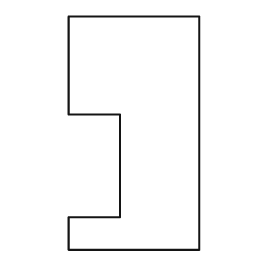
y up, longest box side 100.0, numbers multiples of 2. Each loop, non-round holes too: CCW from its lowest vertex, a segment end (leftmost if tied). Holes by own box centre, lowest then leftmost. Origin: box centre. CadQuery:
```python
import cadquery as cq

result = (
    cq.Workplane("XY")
    .moveTo(-28.0, -50.0)
    .lineTo(28.0, -50.0)
    .lineTo(28.0, 50.0)
    .lineTo(-28.0, 50.0)
    .lineTo(-28.0, 8.0)
    .lineTo(-6.0, 8.0)
    .lineTo(-6.0, -36.0)
    .lineTo(-28.0, -36.0)
    .close()
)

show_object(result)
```